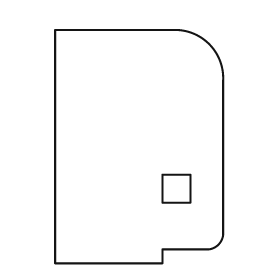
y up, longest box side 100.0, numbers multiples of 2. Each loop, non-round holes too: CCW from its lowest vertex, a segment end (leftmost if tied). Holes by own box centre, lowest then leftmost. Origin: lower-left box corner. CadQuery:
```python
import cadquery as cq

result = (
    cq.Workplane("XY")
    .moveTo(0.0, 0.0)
    .lineTo(46.0, 0.0)
    .lineTo(46.0, 6.0)
    .lineTo(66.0, 6.0)
    .threePointArc((70.0, 8.0), (72.0, 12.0))
    .lineTo(72.0, 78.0)
    .threePointArc((66.0, 94.0), (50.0, 100.0))
    .lineTo(0.0, 100.0)
    .close()
    .moveTo(46.0, 26.0)
    .lineTo(58.0, 26.0)
    .lineTo(58.0, 38.0)
    .lineTo(46.0, 38.0)
    .close()
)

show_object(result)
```